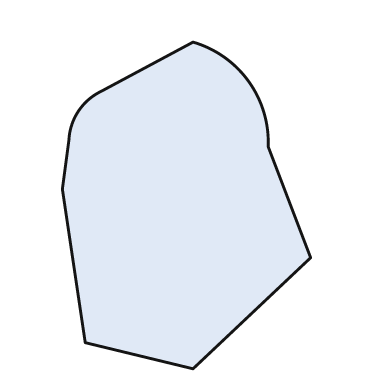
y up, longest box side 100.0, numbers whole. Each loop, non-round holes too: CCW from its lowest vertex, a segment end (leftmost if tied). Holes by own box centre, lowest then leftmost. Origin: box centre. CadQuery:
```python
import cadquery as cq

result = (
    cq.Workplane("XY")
    .moveTo(2.0, -50.0)
    .lineTo(38.0, -16.0)
    .lineTo(25.0, 18.0)
    .threePointArc((19.0, 38.0), (2.0, 50.0))
    .lineTo(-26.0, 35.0)
    .threePointArc((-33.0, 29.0), (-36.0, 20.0))
    .lineTo(-38.0, 5.0)
    .lineTo(-31.0, -42.0)
    .close()
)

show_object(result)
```